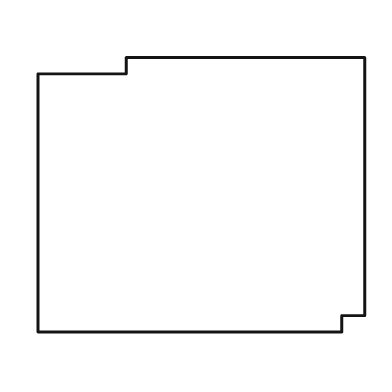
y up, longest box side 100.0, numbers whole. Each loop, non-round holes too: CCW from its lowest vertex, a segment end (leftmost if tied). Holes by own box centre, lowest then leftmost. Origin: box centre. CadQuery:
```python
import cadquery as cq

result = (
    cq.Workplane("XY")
    .moveTo(-50.0, -42.0)
    .lineTo(43.0, -42.0)
    .lineTo(43.0, -37.0)
    .lineTo(50.0, -37.0)
    .lineTo(50.0, 42.0)
    .lineTo(-23.0, 42.0)
    .lineTo(-23.0, 37.0)
    .lineTo(-50.0, 37.0)
    .close()
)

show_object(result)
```